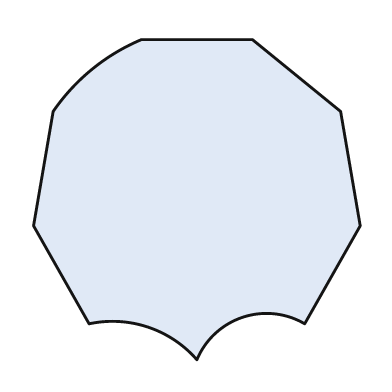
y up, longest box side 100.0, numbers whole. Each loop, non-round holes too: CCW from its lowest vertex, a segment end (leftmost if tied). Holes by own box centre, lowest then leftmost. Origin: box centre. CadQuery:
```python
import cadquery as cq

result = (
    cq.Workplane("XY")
    .moveTo(0.0, -49.0)
    .threePointArc((14.0, -36.0), (33.0, -38.0))
    .lineTo(50.0, -8.0)
    .lineTo(44.0, 27.0)
    .lineTo(17.0, 49.0)
    .lineTo(-17.0, 49.0)
    .threePointArc((-32.0, 40.0), (-44.0, 27.0))
    .lineTo(-50.0, -8.0)
    .lineTo(-33.0, -38.0)
    .threePointArc((-15.0, -39.0), (0.0, -49.0))
    .close()
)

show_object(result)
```